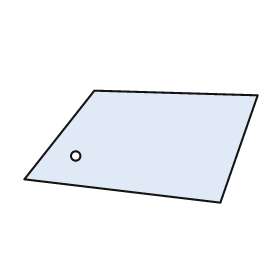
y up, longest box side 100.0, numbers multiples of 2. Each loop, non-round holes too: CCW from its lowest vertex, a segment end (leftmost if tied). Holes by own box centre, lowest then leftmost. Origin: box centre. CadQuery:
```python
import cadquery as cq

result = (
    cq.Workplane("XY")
    .moveTo(34.0, -24.0)
    .lineTo(50.0, 22.0)
    .lineTo(-20.0, 24.0)
    .lineTo(-50.0, -14.0)
    .close()
    .moveTo(-28.0, -4.0)
    .circle(2.0)
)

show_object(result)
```